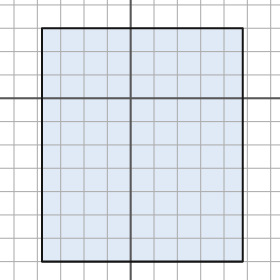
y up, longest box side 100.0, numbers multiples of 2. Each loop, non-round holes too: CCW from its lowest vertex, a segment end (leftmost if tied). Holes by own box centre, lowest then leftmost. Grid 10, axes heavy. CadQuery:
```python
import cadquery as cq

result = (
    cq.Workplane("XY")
    .moveTo(-38.0, -70.0)
    .lineTo(48.0, -70.0)
    .lineTo(48.0, 30.0)
    .lineTo(-38.0, 30.0)
    .close()
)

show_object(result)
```